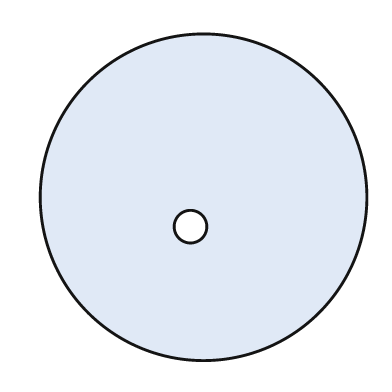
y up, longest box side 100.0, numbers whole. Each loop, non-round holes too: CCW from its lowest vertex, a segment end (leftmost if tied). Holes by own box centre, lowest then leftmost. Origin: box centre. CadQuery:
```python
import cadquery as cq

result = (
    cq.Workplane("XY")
    .moveTo(0.0, 0.0)
    .circle(50.0)
    .moveTo(-4.0, -9.0)
    .circle(5.0)
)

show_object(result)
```